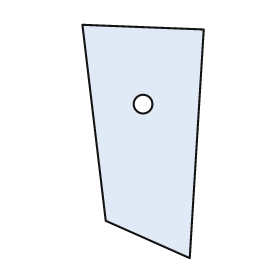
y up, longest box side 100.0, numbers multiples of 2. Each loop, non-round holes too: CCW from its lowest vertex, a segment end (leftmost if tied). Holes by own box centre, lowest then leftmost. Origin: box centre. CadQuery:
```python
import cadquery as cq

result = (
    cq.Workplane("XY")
    .moveTo(20.0, -50.0)
    .lineTo(26.0, 48.0)
    .lineTo(-26.0, 50.0)
    .lineTo(-16.0, -34.0)
    .close()
    .moveTo(0.0, 16.0)
    .circle(4.0)
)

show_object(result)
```